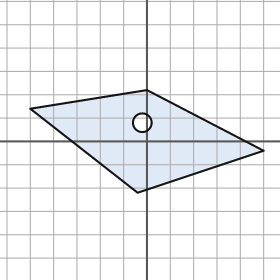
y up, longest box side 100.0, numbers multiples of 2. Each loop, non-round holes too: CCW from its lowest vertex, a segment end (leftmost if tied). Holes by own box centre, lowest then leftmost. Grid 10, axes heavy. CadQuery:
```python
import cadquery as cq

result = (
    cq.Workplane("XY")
    .moveTo(-4.0, -22.0)
    .lineTo(50.0, -4.0)
    .lineTo(0.0, 22.0)
    .lineTo(-50.0, 14.0)
    .close()
    .moveTo(-2.0, 8.0)
    .circle(4.0)
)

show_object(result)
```